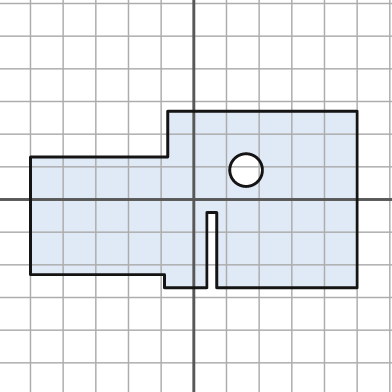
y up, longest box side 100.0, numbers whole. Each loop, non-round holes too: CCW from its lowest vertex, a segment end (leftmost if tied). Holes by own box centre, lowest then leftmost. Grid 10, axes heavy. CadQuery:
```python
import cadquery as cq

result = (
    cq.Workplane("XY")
    .moveTo(-9.0, -27.0)
    .lineTo(4.0, -27.0)
    .lineTo(4.0, -4.0)
    .lineTo(7.0, -4.0)
    .lineTo(7.0, -27.0)
    .lineTo(50.0, -27.0)
    .lineTo(50.0, 27.0)
    .lineTo(-8.0, 27.0)
    .lineTo(-8.0, 13.0)
    .lineTo(-50.0, 13.0)
    .lineTo(-50.0, -23.0)
    .lineTo(-9.0, -23.0)
    .close()
    .moveTo(16.0, 9.0)
    .circle(5.0)
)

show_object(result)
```